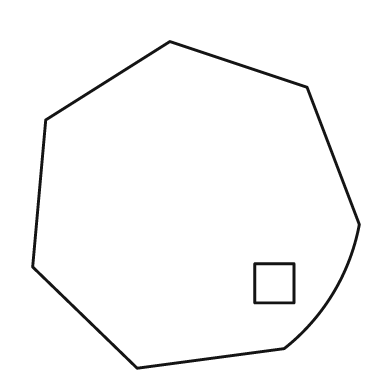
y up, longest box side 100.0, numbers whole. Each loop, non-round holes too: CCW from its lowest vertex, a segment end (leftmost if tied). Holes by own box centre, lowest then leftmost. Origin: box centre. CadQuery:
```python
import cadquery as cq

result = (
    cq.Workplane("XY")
    .moveTo(-18.0, -50.0)
    .lineTo(27.0, -44.0)
    .threePointArc((42.0, -27.0), (50.0, -6.0))
    .lineTo(34.0, 36.0)
    .lineTo(-8.0, 50.0)
    .lineTo(-46.0, 26.0)
    .lineTo(-50.0, -19.0)
    .close()
    .moveTo(18.0, -30.0)
    .lineTo(30.0, -30.0)
    .lineTo(30.0, -18.0)
    .lineTo(18.0, -18.0)
    .close()
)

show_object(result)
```